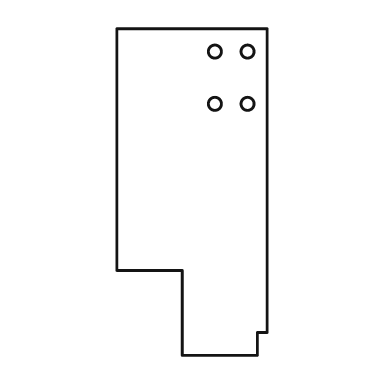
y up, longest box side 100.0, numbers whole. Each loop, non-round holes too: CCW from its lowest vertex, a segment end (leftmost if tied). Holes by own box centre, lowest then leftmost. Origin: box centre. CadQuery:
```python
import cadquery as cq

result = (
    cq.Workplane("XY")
    .moveTo(-3.0, -50.0)
    .lineTo(20.0, -50.0)
    .lineTo(20.0, -43.0)
    .lineTo(23.0, -43.0)
    .lineTo(23.0, 50.0)
    .lineTo(-23.0, 50.0)
    .lineTo(-23.0, -24.0)
    .lineTo(-3.0, -24.0)
    .close()
    .moveTo(7.0, 27.0)
    .circle(2.0)
    .moveTo(17.0, 27.0)
    .circle(2.0)
    .moveTo(7.0, 43.0)
    .circle(2.0)
    .moveTo(17.0, 43.0)
    .circle(2.0)
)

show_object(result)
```